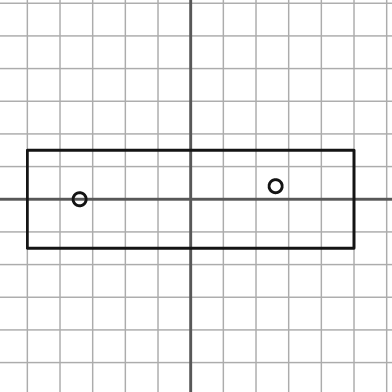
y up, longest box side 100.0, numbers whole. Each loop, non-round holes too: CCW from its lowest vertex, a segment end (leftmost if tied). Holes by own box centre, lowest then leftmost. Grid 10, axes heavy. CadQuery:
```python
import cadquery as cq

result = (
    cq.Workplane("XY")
    .moveTo(-50.0, -15.0)
    .lineTo(50.0, -15.0)
    .lineTo(50.0, 15.0)
    .lineTo(-50.0, 15.0)
    .close()
    .moveTo(-34.0, 0.0)
    .circle(2.0)
    .moveTo(26.0, 4.0)
    .circle(2.0)
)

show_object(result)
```